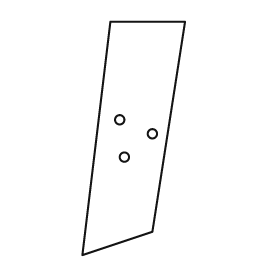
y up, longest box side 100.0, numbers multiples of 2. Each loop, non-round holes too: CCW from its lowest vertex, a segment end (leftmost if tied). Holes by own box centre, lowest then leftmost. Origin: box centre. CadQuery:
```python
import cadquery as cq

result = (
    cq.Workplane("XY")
    .moveTo(-22.0, -50.0)
    .lineTo(8.0, -40.0)
    .lineTo(22.0, 50.0)
    .lineTo(-10.0, 50.0)
    .close()
    .moveTo(-4.0, -8.0)
    .circle(2.0)
    .moveTo(8.0, 2.0)
    .circle(2.0)
    .moveTo(-6.0, 8.0)
    .circle(2.0)
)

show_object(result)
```